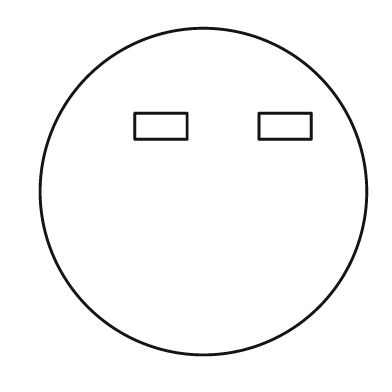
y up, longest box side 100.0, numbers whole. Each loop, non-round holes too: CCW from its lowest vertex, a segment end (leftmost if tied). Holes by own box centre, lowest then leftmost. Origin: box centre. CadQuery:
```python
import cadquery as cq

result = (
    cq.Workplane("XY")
    .moveTo(0.0, 0.0)
    .circle(50.0)
    .moveTo(-21.0, 16.0)
    .lineTo(-5.0, 16.0)
    .lineTo(-5.0, 24.0)
    .lineTo(-21.0, 24.0)
    .close()
    .moveTo(17.0, 16.0)
    .lineTo(33.0, 16.0)
    .lineTo(33.0, 24.0)
    .lineTo(17.0, 24.0)
    .close()
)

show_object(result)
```